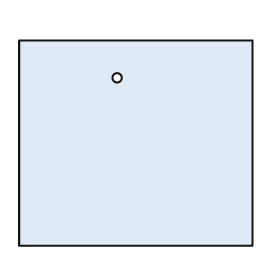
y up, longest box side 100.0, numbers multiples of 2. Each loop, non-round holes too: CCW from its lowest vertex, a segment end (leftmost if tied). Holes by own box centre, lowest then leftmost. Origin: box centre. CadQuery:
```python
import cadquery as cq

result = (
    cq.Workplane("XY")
    .moveTo(-50.0, -44.0)
    .lineTo(50.0, -44.0)
    .lineTo(50.0, 44.0)
    .lineTo(-50.0, 44.0)
    .close()
    .moveTo(-8.0, 28.0)
    .circle(2.0)
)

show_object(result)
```